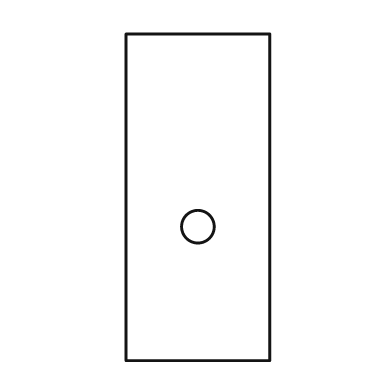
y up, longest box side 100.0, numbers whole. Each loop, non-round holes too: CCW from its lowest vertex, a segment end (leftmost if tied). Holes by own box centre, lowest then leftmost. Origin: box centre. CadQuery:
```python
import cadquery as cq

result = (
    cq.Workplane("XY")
    .moveTo(-22.0, -50.0)
    .lineTo(22.0, -50.0)
    .lineTo(22.0, 50.0)
    .lineTo(-22.0, 50.0)
    .close()
    .moveTo(0.0, -9.0)
    .circle(5.0)
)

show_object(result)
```